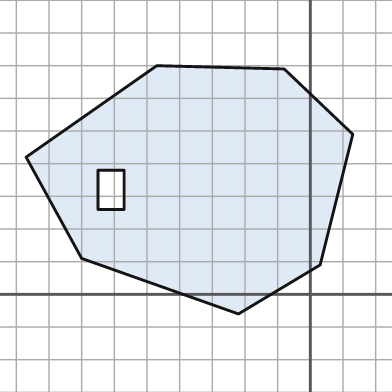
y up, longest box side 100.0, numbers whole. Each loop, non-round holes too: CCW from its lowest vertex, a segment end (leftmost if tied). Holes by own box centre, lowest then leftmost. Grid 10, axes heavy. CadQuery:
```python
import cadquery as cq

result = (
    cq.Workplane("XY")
    .moveTo(-22.0, -6.0)
    .lineTo(3.0, 9.0)
    .lineTo(13.0, 49.0)
    .lineTo(-8.0, 69.0)
    .lineTo(-47.0, 70.0)
    .lineTo(-87.0, 42.0)
    .lineTo(-70.0, 11.0)
    .close()
    .moveTo(-65.0, 26.0)
    .lineTo(-57.0, 26.0)
    .lineTo(-57.0, 38.0)
    .lineTo(-65.0, 38.0)
    .close()
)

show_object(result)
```